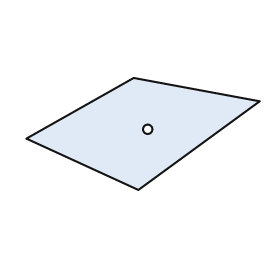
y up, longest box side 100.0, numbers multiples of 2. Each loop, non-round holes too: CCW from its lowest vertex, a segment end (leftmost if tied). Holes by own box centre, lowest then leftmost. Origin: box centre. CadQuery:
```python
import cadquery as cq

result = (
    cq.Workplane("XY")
    .moveTo(-2.0, -24.0)
    .lineTo(50.0, 14.0)
    .lineTo(-4.0, 24.0)
    .lineTo(-50.0, -2.0)
    .close()
    .moveTo(2.0, 2.0)
    .circle(2.0)
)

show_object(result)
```